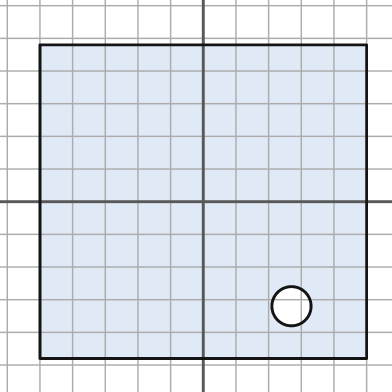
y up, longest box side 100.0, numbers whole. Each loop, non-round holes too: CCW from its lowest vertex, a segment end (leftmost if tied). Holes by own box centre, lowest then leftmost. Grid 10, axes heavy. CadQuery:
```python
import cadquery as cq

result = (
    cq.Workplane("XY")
    .moveTo(-50.0, -48.0)
    .lineTo(50.0, -48.0)
    .lineTo(50.0, 48.0)
    .lineTo(-50.0, 48.0)
    .close()
    .moveTo(27.0, -32.0)
    .circle(6.0)
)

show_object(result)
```